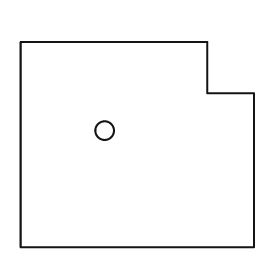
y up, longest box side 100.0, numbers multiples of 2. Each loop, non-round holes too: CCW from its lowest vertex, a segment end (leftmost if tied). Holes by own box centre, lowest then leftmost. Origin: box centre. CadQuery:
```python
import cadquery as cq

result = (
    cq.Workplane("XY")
    .moveTo(-50.0, -44.0)
    .lineTo(50.0, -44.0)
    .lineTo(50.0, 22.0)
    .lineTo(30.0, 22.0)
    .lineTo(30.0, 44.0)
    .lineTo(-50.0, 44.0)
    .close()
    .moveTo(-14.0, 6.0)
    .circle(4.0)
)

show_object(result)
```